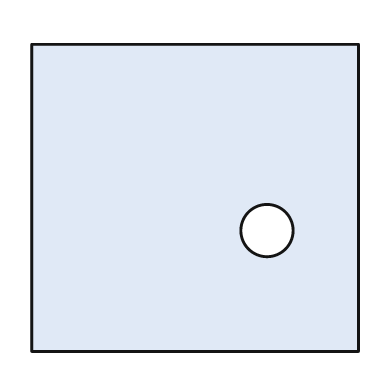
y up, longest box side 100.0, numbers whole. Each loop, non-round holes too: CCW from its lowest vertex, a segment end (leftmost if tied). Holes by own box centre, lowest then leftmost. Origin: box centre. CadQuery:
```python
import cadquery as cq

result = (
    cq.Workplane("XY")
    .moveTo(-50.0, -47.0)
    .lineTo(50.0, -47.0)
    .lineTo(50.0, 47.0)
    .lineTo(-50.0, 47.0)
    .close()
    .moveTo(22.0, -10.0)
    .circle(8.0)
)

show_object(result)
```